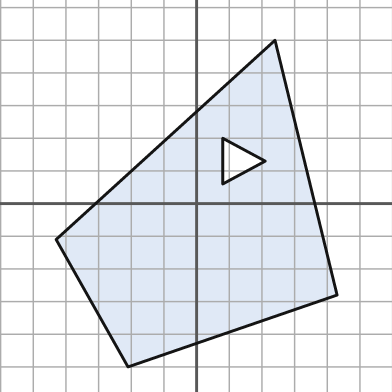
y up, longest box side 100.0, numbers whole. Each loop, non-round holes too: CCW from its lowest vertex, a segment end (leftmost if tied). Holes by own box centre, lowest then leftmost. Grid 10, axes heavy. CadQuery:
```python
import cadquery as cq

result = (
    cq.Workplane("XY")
    .moveTo(-21.0, -50.0)
    .lineTo(43.0, -28.0)
    .lineTo(24.0, 50.0)
    .lineTo(-43.0, -11.0)
    .close()
    .moveTo(8.0, 6.0)
    .lineTo(21.0, 13.0)
    .lineTo(8.0, 20.0)
    .close()
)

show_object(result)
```